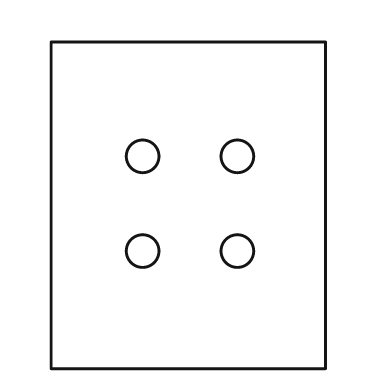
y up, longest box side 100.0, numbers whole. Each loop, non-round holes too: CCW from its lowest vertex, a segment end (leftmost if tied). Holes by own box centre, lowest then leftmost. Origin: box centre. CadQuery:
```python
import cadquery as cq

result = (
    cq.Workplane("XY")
    .moveTo(-42.0, -50.0)
    .lineTo(42.0, -50.0)
    .lineTo(42.0, 50.0)
    .lineTo(-42.0, 50.0)
    .close()
    .moveTo(-14.0, -14.0)
    .circle(5.0)
    .moveTo(15.0, -14.0)
    .circle(5.0)
    .moveTo(-14.0, 15.0)
    .circle(5.0)
    .moveTo(15.0, 15.0)
    .circle(5.0)
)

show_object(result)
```